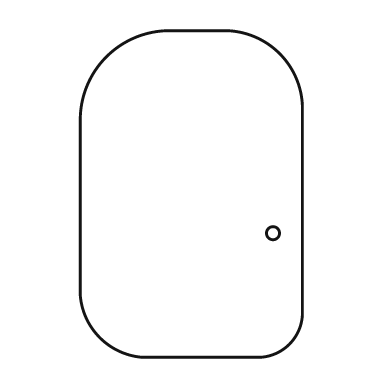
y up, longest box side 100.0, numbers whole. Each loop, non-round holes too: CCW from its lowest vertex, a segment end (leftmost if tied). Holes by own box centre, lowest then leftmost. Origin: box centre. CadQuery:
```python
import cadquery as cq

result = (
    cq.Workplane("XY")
    .moveTo(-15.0, -50.0)
    .lineTo(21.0, -50.0)
    .threePointArc((30.0, -46.0), (34.0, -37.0))
    .lineTo(34.0, 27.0)
    .threePointArc((27.0, 43.0), (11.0, 50.0))
    .lineTo(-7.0, 50.0)
    .threePointArc((-26.0, 42.0), (-34.0, 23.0))
    .lineTo(-34.0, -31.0)
    .threePointArc((-28.0, -44.0), (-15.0, -50.0))
    .close()
    .moveTo(25.0, -12.0)
    .circle(2.0)
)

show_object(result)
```